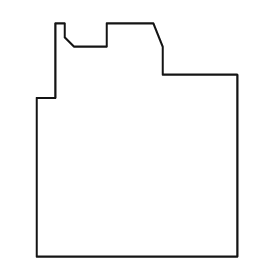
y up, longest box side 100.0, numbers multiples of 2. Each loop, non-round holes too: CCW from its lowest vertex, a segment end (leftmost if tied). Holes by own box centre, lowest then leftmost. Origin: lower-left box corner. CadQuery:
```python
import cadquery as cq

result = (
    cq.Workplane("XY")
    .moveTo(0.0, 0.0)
    .lineTo(86.0, 0.0)
    .lineTo(86.0, 78.0)
    .lineTo(54.0, 78.0)
    .lineTo(54.0, 90.0)
    .lineTo(50.0, 100.0)
    .lineTo(30.0, 100.0)
    .lineTo(30.0, 90.0)
    .lineTo(16.0, 90.0)
    .lineTo(12.0, 94.0)
    .lineTo(12.0, 100.0)
    .lineTo(8.0, 100.0)
    .lineTo(8.0, 68.0)
    .lineTo(0.0, 68.0)
    .close()
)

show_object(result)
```